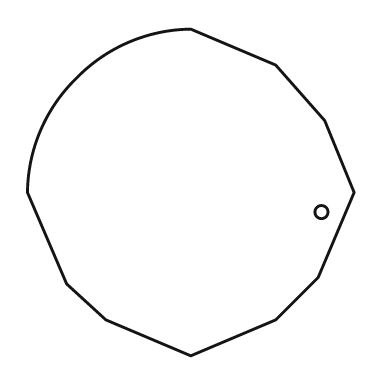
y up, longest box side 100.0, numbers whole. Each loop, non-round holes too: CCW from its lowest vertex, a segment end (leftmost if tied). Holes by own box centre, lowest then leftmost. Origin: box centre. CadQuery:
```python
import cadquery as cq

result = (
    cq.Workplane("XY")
    .moveTo(0.0, -50.0)
    .lineTo(26.0, -39.0)
    .lineTo(39.0, -26.0)
    .lineTo(50.0, 0.0)
    .lineTo(41.0, 22.0)
    .lineTo(26.0, 39.0)
    .lineTo(0.0, 50.0)
    .threePointArc((-19.0, 46.0), (-35.0, 35.0))
    .threePointArc((-46.0, 19.0), (-50.0, 0.0))
    .lineTo(-38.0, -28.0)
    .lineTo(-26.0, -39.0)
    .close()
    .moveTo(40.0, -6.0)
    .circle(2.0)
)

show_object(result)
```